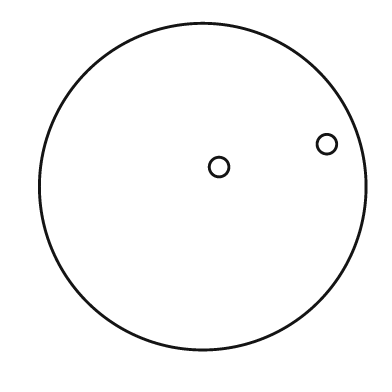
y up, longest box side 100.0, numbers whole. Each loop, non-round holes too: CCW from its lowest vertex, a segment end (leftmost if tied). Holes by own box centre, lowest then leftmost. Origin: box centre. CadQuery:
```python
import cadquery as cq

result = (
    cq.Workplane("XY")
    .moveTo(0.0, 0.0)
    .circle(50.0)
    .moveTo(5.0, 6.0)
    .circle(3.0)
    .moveTo(38.0, 13.0)
    .circle(3.0)
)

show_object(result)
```